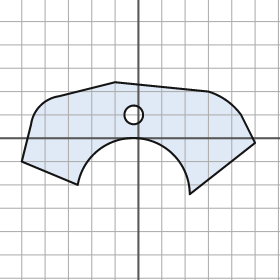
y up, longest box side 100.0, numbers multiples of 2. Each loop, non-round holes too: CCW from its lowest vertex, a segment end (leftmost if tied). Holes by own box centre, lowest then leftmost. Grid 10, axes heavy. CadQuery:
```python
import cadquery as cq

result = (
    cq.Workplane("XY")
    .moveTo(22.0, -24.0)
    .lineTo(50.0, -2.0)
    .lineTo(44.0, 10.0)
    .threePointArc((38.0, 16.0), (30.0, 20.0))
    .lineTo(-10.0, 24.0)
    .lineTo(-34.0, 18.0)
    .threePointArc((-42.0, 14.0), (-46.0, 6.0))
    .lineTo(-50.0, -10.0)
    .lineTo(-26.0, -20.0)
    .threePointArc((0.0, 0.0), (22.0, -24.0))
    .close()
    .moveTo(-2.0, 10.0)
    .circle(4.0)
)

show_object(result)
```